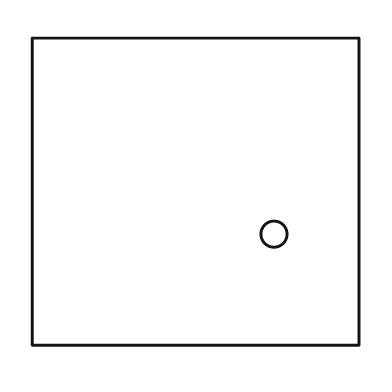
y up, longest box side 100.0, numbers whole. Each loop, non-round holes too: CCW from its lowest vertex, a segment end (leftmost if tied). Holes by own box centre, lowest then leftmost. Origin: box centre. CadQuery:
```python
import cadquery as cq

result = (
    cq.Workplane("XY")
    .moveTo(-50.0, -47.0)
    .lineTo(50.0, -47.0)
    .lineTo(50.0, 47.0)
    .lineTo(-50.0, 47.0)
    .close()
    .moveTo(24.0, -13.0)
    .circle(4.0)
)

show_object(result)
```